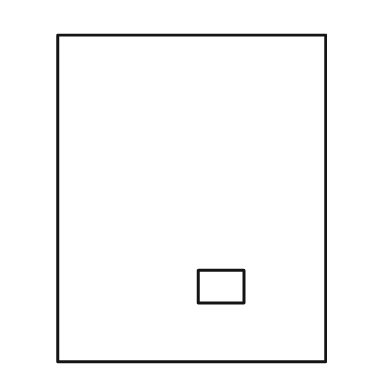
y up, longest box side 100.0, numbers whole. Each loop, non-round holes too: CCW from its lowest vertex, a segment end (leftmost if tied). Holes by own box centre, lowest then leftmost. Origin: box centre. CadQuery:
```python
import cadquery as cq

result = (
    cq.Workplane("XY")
    .moveTo(-41.0, -50.0)
    .lineTo(41.0, -50.0)
    .lineTo(41.0, 50.0)
    .lineTo(-41.0, 50.0)
    .close()
    .moveTo(2.0, -32.0)
    .lineTo(16.0, -32.0)
    .lineTo(16.0, -22.0)
    .lineTo(2.0, -22.0)
    .close()
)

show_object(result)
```